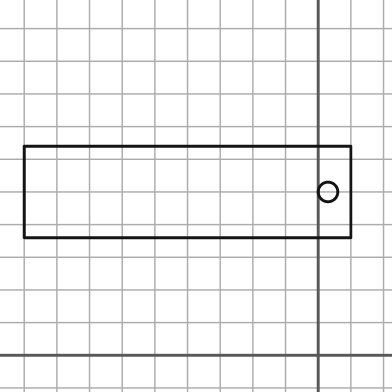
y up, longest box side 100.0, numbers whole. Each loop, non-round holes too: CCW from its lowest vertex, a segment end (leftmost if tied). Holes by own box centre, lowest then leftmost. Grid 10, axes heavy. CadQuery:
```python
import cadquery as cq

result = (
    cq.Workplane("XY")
    .moveTo(-90.0, 36.0)
    .lineTo(10.0, 36.0)
    .lineTo(10.0, 64.0)
    .lineTo(-90.0, 64.0)
    .close()
    .moveTo(3.0, 50.0)
    .circle(3.0)
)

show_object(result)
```